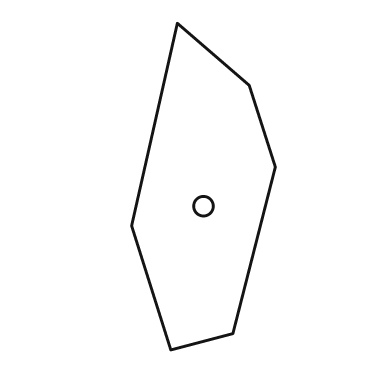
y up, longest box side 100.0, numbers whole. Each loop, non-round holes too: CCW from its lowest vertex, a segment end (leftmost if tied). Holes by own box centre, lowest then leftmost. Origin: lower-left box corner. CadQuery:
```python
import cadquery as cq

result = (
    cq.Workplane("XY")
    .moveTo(12.0, 0.0)
    .lineTo(31.0, 5.0)
    .lineTo(44.0, 56.0)
    .lineTo(36.0, 81.0)
    .lineTo(14.0, 100.0)
    .lineTo(0.0, 38.0)
    .close()
    .moveTo(22.0, 44.0)
    .circle(3.0)
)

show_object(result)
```